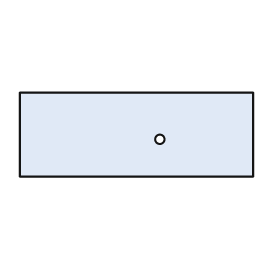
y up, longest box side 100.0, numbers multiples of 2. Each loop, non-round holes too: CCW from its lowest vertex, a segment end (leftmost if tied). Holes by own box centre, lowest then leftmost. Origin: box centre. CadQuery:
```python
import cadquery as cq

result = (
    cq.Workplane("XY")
    .moveTo(-50.0, -18.0)
    .lineTo(50.0, -18.0)
    .lineTo(50.0, 18.0)
    .lineTo(-50.0, 18.0)
    .close()
    .moveTo(10.0, -2.0)
    .circle(2.0)
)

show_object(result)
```